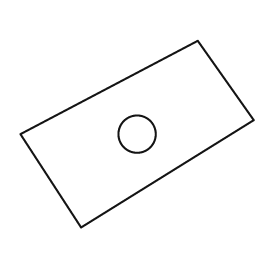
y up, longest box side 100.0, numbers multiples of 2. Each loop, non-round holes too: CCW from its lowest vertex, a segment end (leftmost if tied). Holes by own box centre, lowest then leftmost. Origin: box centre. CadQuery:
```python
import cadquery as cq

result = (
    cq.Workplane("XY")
    .moveTo(-24.0, -40.0)
    .lineTo(50.0, 6.0)
    .lineTo(26.0, 40.0)
    .lineTo(-50.0, 0.0)
    .close()
    .moveTo(0.0, 0.0)
    .circle(8.0)
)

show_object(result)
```